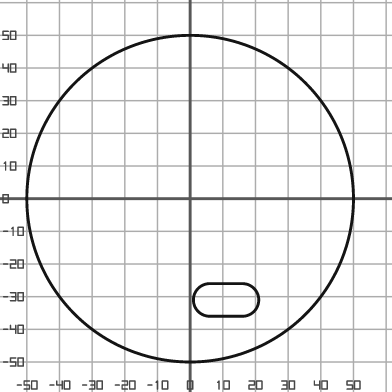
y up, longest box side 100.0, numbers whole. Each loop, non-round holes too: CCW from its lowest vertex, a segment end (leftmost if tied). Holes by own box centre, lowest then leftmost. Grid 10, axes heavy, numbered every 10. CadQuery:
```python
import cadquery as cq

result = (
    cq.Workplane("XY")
    .moveTo(0.0, 0.0)
    .circle(50.0)
    .moveTo(6.0, -36.0)
    .lineTo(16.0, -36.0)
    .threePointArc((21.0, -31.0), (16.0, -26.0))
    .lineTo(6.0, -26.0)
    .threePointArc((1.0, -31.0), (6.0, -36.0))
    .close()
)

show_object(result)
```